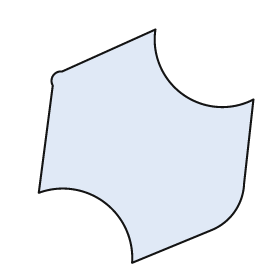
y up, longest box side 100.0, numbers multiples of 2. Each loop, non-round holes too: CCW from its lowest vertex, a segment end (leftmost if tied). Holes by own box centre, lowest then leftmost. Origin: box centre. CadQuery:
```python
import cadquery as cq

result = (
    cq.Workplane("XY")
    .moveTo(-6.0, -50.0)
    .lineTo(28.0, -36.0)
    .threePointArc((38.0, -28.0), (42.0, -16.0))
    .lineTo(46.0, 20.0)
    .threePointArc((16.0, 22.0), (4.0, 50.0))
    .lineTo(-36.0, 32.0)
    .threePointArc((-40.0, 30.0), (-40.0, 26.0))
    .lineTo(-46.0, -20.0)
    .threePointArc((-18.0, -24.0), (-6.0, -50.0))
    .close()
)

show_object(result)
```